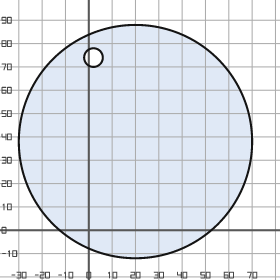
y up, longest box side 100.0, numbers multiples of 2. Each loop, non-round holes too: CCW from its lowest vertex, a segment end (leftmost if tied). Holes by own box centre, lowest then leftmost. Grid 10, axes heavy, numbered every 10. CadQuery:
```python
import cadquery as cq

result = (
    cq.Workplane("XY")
    .moveTo(20.0, 38.0)
    .circle(50.0)
    .moveTo(2.0, 74.0)
    .circle(4.0)
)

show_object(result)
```